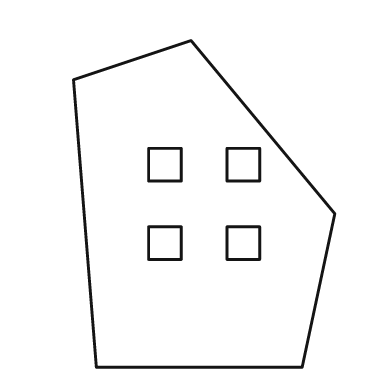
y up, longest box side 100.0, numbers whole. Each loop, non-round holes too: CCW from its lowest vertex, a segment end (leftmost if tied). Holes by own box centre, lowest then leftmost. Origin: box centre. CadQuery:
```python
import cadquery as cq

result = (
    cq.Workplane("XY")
    .moveTo(-33.0, -50.0)
    .lineTo(30.0, -50.0)
    .lineTo(40.0, -3.0)
    .lineTo(-4.0, 50.0)
    .lineTo(-40.0, 38.0)
    .close()
    .moveTo(-17.0, -17.0)
    .lineTo(-7.0, -17.0)
    .lineTo(-7.0, -7.0)
    .lineTo(-17.0, -7.0)
    .close()
    .moveTo(7.0, -17.0)
    .lineTo(17.0, -17.0)
    .lineTo(17.0, -7.0)
    .lineTo(7.0, -7.0)
    .close()
    .moveTo(-17.0, 7.0)
    .lineTo(-7.0, 7.0)
    .lineTo(-7.0, 17.0)
    .lineTo(-17.0, 17.0)
    .close()
    .moveTo(7.0, 7.0)
    .lineTo(17.0, 7.0)
    .lineTo(17.0, 17.0)
    .lineTo(7.0, 17.0)
    .close()
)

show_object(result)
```